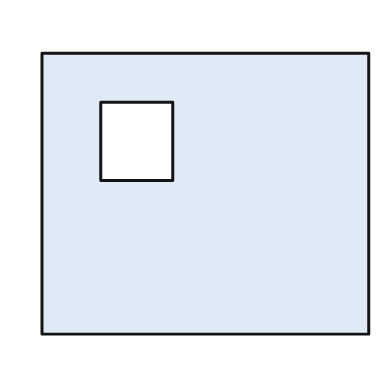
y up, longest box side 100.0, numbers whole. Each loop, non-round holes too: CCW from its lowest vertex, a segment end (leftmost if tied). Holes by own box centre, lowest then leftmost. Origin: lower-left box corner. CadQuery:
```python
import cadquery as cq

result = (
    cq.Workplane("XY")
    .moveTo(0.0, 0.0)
    .lineTo(100.0, 0.0)
    .lineTo(100.0, 86.0)
    .lineTo(0.0, 86.0)
    .close()
    .moveTo(18.0, 47.0)
    .lineTo(40.0, 47.0)
    .lineTo(40.0, 71.0)
    .lineTo(18.0, 71.0)
    .close()
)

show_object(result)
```